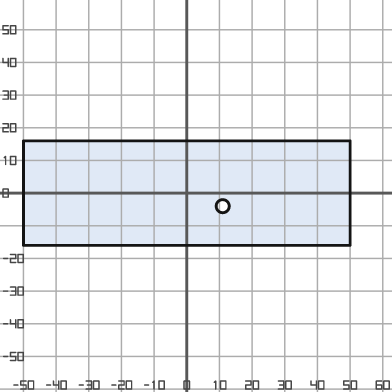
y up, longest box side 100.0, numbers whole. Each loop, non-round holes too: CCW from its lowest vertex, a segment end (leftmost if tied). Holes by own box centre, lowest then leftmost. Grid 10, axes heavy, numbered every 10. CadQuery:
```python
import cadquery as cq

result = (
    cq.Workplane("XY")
    .moveTo(-50.0, -16.0)
    .lineTo(50.0, -16.0)
    .lineTo(50.0, 16.0)
    .lineTo(-50.0, 16.0)
    .close()
    .moveTo(11.0, -4.0)
    .circle(2.0)
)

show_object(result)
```